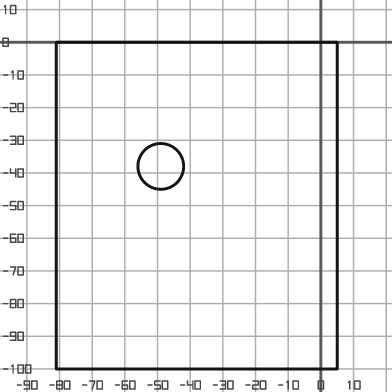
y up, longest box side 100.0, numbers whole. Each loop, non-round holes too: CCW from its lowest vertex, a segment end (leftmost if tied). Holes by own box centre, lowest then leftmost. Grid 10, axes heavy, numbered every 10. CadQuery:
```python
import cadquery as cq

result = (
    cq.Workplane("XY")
    .moveTo(-81.0, -100.0)
    .lineTo(5.0, -100.0)
    .lineTo(5.0, 0.0)
    .lineTo(-81.0, 0.0)
    .close()
    .moveTo(-49.0, -38.0)
    .circle(7.0)
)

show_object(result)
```